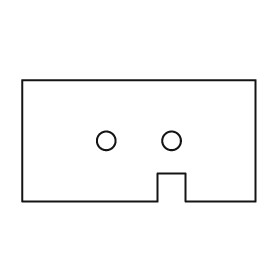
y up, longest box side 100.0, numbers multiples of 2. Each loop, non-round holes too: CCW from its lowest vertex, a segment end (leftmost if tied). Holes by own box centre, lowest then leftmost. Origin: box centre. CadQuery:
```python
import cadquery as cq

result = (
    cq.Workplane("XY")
    .moveTo(-50.0, -26.0)
    .lineTo(8.0, -26.0)
    .lineTo(8.0, -14.0)
    .lineTo(20.0, -14.0)
    .lineTo(20.0, -26.0)
    .lineTo(50.0, -26.0)
    .lineTo(50.0, 26.0)
    .lineTo(-50.0, 26.0)
    .close()
    .moveTo(-14.0, 0.0)
    .circle(4.0)
    .moveTo(14.0, 0.0)
    .circle(4.0)
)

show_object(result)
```